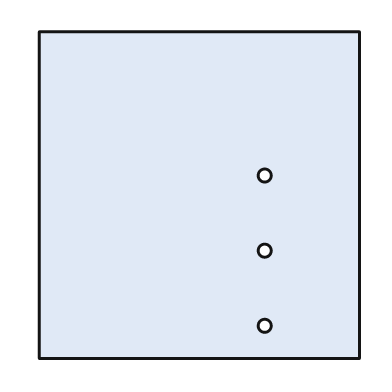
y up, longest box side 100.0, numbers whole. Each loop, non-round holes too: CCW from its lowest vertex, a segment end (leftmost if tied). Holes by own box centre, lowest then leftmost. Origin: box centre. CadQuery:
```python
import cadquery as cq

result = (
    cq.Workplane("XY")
    .moveTo(-49.0, -50.0)
    .lineTo(49.0, -50.0)
    .lineTo(49.0, 50.0)
    .lineTo(-49.0, 50.0)
    .close()
    .moveTo(20.0, -40.0)
    .circle(2.0)
    .moveTo(20.0, -17.0)
    .circle(2.0)
    .moveTo(20.0, 6.0)
    .circle(2.0)
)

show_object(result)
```